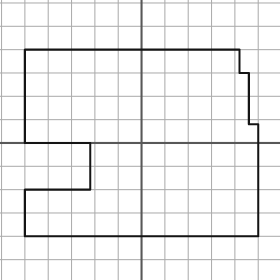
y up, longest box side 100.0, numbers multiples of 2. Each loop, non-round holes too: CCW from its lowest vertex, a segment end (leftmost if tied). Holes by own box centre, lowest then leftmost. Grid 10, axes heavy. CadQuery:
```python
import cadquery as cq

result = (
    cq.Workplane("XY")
    .moveTo(-50.0, -40.0)
    .lineTo(50.0, -40.0)
    .lineTo(50.0, 8.0)
    .lineTo(46.0, 8.0)
    .lineTo(46.0, 30.0)
    .lineTo(42.0, 30.0)
    .lineTo(42.0, 40.0)
    .lineTo(-50.0, 40.0)
    .lineTo(-50.0, 0.0)
    .lineTo(-22.0, 0.0)
    .lineTo(-22.0, -20.0)
    .lineTo(-50.0, -20.0)
    .close()
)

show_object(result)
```